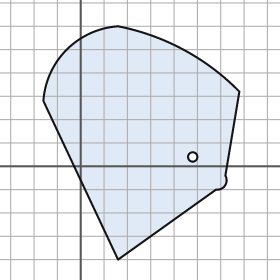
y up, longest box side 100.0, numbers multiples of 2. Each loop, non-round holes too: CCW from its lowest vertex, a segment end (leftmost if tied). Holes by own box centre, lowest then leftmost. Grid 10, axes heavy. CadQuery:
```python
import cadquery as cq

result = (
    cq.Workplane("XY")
    .moveTo(16.0, -40.0)
    .lineTo(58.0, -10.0)
    .threePointArc((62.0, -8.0), (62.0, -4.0))
    .lineTo(68.0, 32.0)
    .threePointArc((44.0, 50.0), (16.0, 60.0))
    .threePointArc((-6.0, 50.0), (-16.0, 28.0))
    .close()
    .moveTo(48.0, 4.0)
    .circle(2.0)
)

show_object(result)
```